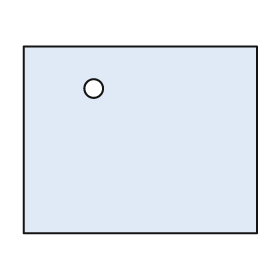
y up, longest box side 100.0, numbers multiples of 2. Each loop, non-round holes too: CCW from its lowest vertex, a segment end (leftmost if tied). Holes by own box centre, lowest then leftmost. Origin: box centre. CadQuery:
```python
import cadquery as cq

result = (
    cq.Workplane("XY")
    .moveTo(-50.0, -40.0)
    .lineTo(50.0, -40.0)
    .lineTo(50.0, 40.0)
    .lineTo(-50.0, 40.0)
    .close()
    .moveTo(-20.0, 22.0)
    .circle(4.0)
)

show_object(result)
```